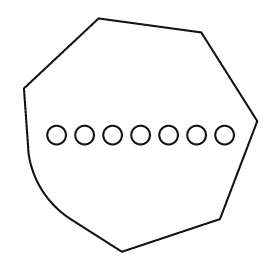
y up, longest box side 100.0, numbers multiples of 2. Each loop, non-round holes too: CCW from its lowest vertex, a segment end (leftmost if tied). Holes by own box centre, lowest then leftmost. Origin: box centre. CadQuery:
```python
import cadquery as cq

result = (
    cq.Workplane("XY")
    .moveTo(-8.0, -50.0)
    .lineTo(34.0, -36.0)
    .lineTo(50.0, 6.0)
    .lineTo(26.0, 44.0)
    .lineTo(-18.0, 50.0)
    .lineTo(-50.0, 20.0)
    .lineTo(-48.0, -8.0)
    .threePointArc((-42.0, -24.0), (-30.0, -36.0))
    .close()
    .moveTo(-36.0, 0.0)
    .circle(4.0)
    .moveTo(-24.0, 0.0)
    .circle(4.0)
    .moveTo(-12.0, 0.0)
    .circle(4.0)
    .moveTo(0.0, 0.0)
    .circle(4.0)
    .moveTo(12.0, 0.0)
    .circle(4.0)
    .moveTo(24.0, 0.0)
    .circle(4.0)
    .moveTo(36.0, 0.0)
    .circle(4.0)
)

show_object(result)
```